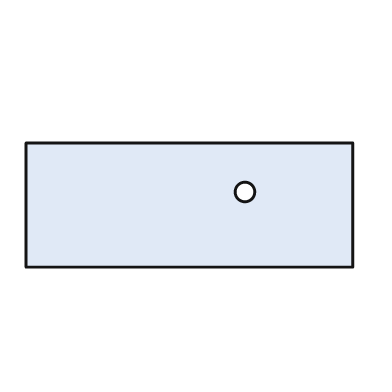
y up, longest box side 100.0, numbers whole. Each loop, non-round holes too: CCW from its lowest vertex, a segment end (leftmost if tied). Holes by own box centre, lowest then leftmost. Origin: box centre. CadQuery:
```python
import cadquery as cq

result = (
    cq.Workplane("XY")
    .moveTo(-50.0, -19.0)
    .lineTo(50.0, -19.0)
    .lineTo(50.0, 19.0)
    .lineTo(-50.0, 19.0)
    .close()
    .moveTo(17.0, 4.0)
    .circle(3.0)
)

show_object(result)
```